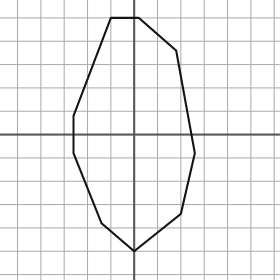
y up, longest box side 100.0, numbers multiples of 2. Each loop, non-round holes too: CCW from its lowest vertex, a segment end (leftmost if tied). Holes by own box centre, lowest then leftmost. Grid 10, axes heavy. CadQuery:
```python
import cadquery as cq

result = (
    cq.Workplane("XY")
    .moveTo(0.0, -50.0)
    .lineTo(20.0, -34.0)
    .lineTo(26.0, -8.0)
    .lineTo(18.0, 36.0)
    .lineTo(2.0, 50.0)
    .lineTo(-10.0, 50.0)
    .lineTo(-26.0, 8.0)
    .lineTo(-26.0, -8.0)
    .lineTo(-14.0, -38.0)
    .close()
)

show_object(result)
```